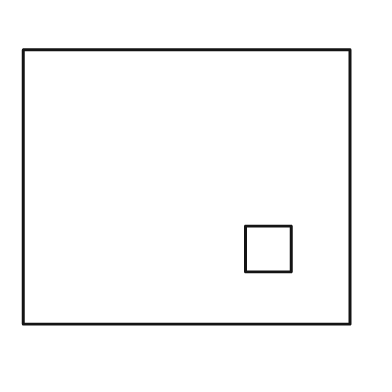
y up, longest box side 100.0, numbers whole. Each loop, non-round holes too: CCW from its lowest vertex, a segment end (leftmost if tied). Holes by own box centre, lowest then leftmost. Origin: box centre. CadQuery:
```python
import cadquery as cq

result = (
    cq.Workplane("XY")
    .moveTo(-50.0, -42.0)
    .lineTo(50.0, -42.0)
    .lineTo(50.0, 42.0)
    .lineTo(-50.0, 42.0)
    .close()
    .moveTo(18.0, -26.0)
    .lineTo(32.0, -26.0)
    .lineTo(32.0, -12.0)
    .lineTo(18.0, -12.0)
    .close()
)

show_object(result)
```